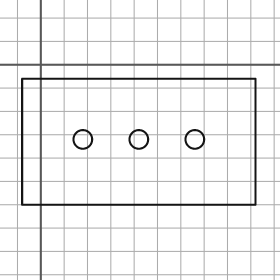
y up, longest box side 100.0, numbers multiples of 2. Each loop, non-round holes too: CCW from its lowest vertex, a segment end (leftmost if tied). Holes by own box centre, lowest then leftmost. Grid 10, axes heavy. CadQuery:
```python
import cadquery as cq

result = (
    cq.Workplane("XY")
    .moveTo(-8.0, -60.0)
    .lineTo(92.0, -60.0)
    .lineTo(92.0, -6.0)
    .lineTo(-8.0, -6.0)
    .close()
    .moveTo(18.0, -32.0)
    .circle(4.0)
    .moveTo(42.0, -32.0)
    .circle(4.0)
    .moveTo(66.0, -32.0)
    .circle(4.0)
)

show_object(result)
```